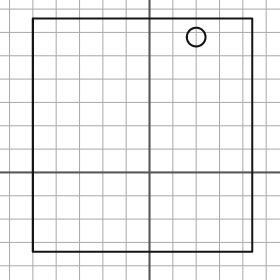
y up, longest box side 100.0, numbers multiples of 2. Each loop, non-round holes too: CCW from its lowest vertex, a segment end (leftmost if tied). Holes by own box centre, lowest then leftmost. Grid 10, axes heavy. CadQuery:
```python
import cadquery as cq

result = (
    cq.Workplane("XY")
    .moveTo(-50.0, -34.0)
    .lineTo(44.0, -34.0)
    .lineTo(44.0, 66.0)
    .lineTo(-50.0, 66.0)
    .close()
    .moveTo(20.0, 58.0)
    .circle(4.0)
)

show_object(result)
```